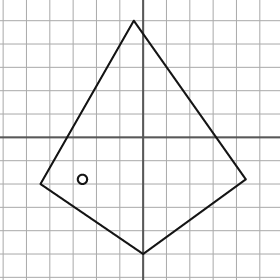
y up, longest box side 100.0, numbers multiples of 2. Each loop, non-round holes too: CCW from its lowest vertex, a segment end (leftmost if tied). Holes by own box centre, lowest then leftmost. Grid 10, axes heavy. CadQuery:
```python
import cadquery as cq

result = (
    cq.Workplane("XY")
    .moveTo(0.0, -50.0)
    .lineTo(44.0, -18.0)
    .lineTo(-4.0, 50.0)
    .lineTo(-44.0, -20.0)
    .close()
    .moveTo(-26.0, -18.0)
    .circle(2.0)
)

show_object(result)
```